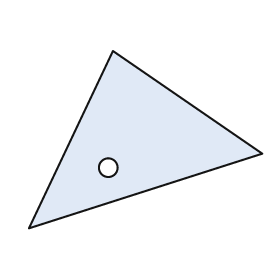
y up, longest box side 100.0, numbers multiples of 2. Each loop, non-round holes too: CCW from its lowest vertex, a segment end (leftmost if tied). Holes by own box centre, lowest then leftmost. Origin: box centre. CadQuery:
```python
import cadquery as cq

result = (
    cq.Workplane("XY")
    .moveTo(-50.0, -38.0)
    .lineTo(50.0, -6.0)
    .lineTo(-14.0, 38.0)
    .close()
    .moveTo(-16.0, -12.0)
    .circle(4.0)
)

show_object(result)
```